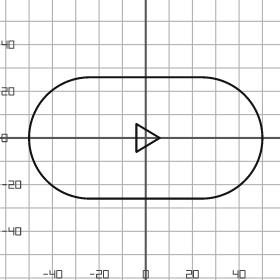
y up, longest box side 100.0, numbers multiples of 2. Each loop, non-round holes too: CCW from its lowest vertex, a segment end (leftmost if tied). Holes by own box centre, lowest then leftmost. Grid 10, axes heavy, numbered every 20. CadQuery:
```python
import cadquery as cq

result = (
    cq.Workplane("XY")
    .moveTo(-24.0, -26.0)
    .lineTo(24.0, -26.0)
    .threePointArc((50.0, 0.0), (24.0, 26.0))
    .lineTo(-24.0, 26.0)
    .threePointArc((-50.0, 0.0), (-24.0, -26.0))
    .close()
    .moveTo(-4.0, -6.0)
    .lineTo(6.0, 0.0)
    .lineTo(-4.0, 6.0)
    .close()
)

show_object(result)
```